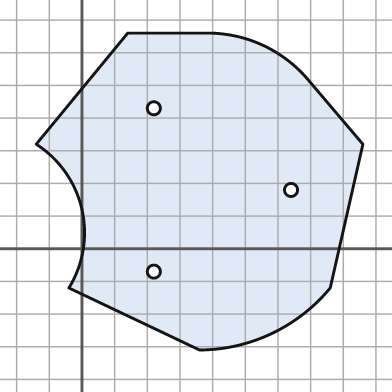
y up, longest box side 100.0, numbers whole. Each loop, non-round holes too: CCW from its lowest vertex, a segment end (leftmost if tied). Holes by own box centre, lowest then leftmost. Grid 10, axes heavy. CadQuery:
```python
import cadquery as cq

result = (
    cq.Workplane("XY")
    .moveTo(36.0, -31.0)
    .threePointArc((58.0, -26.0), (76.0, -12.0))
    .lineTo(86.0, 32.0)
    .lineTo(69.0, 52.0)
    .threePointArc((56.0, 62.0), (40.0, 66.0))
    .lineTo(14.0, 66.0)
    .lineTo(-14.0, 32.0)
    .threePointArc((0.0, 12.0), (-4.0, -12.0))
    .close()
    .moveTo(22.0, -7.0)
    .circle(2.0)
    .moveTo(64.0, 18.0)
    .circle(2.0)
    .moveTo(22.0, 43.0)
    .circle(2.0)
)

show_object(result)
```